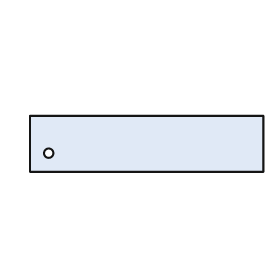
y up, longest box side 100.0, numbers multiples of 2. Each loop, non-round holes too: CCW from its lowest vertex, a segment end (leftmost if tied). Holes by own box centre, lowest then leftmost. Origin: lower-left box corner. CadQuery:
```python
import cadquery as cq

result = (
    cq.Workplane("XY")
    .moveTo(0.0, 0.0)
    .lineTo(100.0, 0.0)
    .lineTo(100.0, 24.0)
    .lineTo(0.0, 24.0)
    .close()
    .moveTo(8.0, 8.0)
    .circle(2.0)
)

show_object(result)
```